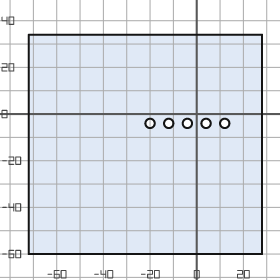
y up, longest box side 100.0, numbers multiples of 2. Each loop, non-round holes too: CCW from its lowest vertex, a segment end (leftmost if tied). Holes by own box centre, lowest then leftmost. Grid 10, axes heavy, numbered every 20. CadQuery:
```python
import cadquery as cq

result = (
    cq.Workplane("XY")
    .moveTo(-72.0, -60.0)
    .lineTo(28.0, -60.0)
    .lineTo(28.0, 34.0)
    .lineTo(-72.0, 34.0)
    .close()
    .moveTo(-20.0, -4.0)
    .circle(2.0)
    .moveTo(-12.0, -4.0)
    .circle(2.0)
    .moveTo(-4.0, -4.0)
    .circle(2.0)
    .moveTo(4.0, -4.0)
    .circle(2.0)
    .moveTo(12.0, -4.0)
    .circle(2.0)
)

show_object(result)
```